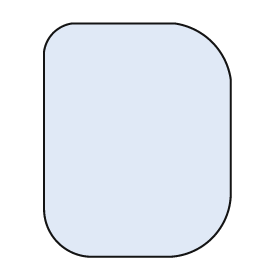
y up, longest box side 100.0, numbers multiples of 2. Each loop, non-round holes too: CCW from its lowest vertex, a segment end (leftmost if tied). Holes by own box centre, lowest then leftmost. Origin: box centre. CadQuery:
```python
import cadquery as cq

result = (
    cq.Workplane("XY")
    .moveTo(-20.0, -50.0)
    .lineTo(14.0, -50.0)
    .threePointArc((32.0, -42.0), (40.0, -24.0))
    .lineTo(40.0, 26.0)
    .threePointArc((32.0, 42.0), (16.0, 50.0))
    .lineTo(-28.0, 50.0)
    .threePointArc((-36.0, 46.0), (-40.0, 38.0))
    .lineTo(-40.0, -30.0)
    .threePointArc((-34.0, -44.0), (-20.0, -50.0))
    .close()
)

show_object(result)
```